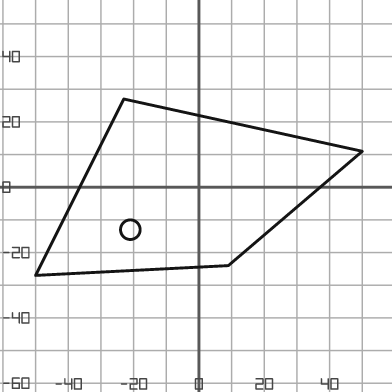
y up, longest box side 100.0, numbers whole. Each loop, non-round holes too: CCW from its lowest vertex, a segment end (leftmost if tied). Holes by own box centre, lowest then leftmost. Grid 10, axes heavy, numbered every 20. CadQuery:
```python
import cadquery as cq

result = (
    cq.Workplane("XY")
    .moveTo(-50.0, -27.0)
    .lineTo(9.0, -24.0)
    .lineTo(50.0, 11.0)
    .lineTo(-23.0, 27.0)
    .close()
    .moveTo(-21.0, -13.0)
    .circle(3.0)
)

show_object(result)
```